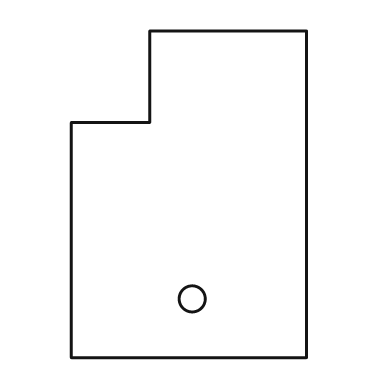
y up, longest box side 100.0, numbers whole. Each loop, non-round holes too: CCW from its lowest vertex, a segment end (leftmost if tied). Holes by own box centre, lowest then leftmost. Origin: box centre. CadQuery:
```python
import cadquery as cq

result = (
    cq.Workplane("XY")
    .moveTo(-36.0, -50.0)
    .lineTo(36.0, -50.0)
    .lineTo(36.0, 50.0)
    .lineTo(-12.0, 50.0)
    .lineTo(-12.0, 22.0)
    .lineTo(-36.0, 22.0)
    .close()
    .moveTo(1.0, -32.0)
    .circle(4.0)
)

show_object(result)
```